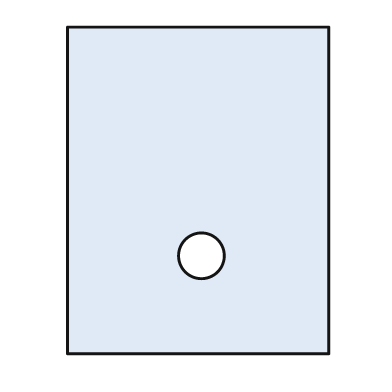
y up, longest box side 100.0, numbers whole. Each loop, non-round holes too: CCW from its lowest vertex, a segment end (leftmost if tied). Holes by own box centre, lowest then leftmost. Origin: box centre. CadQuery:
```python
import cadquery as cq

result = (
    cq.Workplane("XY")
    .moveTo(-40.0, -50.0)
    .lineTo(40.0, -50.0)
    .lineTo(40.0, 50.0)
    .lineTo(-40.0, 50.0)
    .close()
    .moveTo(1.0, -20.0)
    .circle(7.0)
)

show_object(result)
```